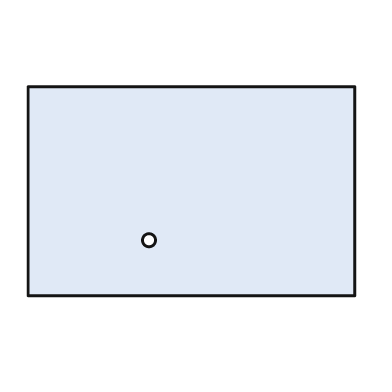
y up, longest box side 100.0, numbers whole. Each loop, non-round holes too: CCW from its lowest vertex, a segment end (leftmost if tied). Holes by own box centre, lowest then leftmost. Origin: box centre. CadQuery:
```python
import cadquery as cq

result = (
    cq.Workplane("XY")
    .moveTo(-50.0, -32.0)
    .lineTo(50.0, -32.0)
    .lineTo(50.0, 32.0)
    .lineTo(-50.0, 32.0)
    .close()
    .moveTo(-13.0, -15.0)
    .circle(2.0)
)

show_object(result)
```